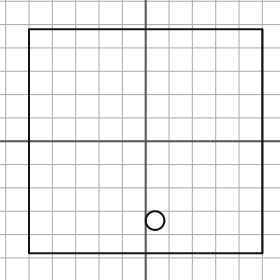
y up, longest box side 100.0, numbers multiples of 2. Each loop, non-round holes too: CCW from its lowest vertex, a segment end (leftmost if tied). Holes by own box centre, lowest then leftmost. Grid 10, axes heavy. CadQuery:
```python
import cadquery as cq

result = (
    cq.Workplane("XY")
    .moveTo(-50.0, -48.0)
    .lineTo(50.0, -48.0)
    .lineTo(50.0, 48.0)
    .lineTo(-50.0, 48.0)
    .close()
    .moveTo(4.0, -34.0)
    .circle(4.0)
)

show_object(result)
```